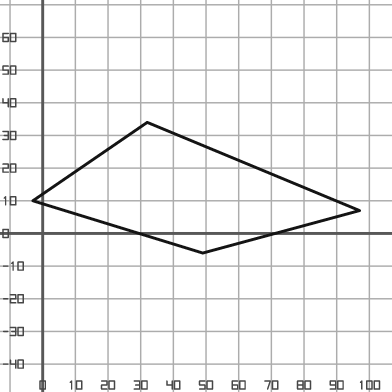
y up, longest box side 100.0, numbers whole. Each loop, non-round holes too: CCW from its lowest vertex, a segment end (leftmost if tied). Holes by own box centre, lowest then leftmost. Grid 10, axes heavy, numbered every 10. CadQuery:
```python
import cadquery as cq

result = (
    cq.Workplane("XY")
    .moveTo(49.0, -6.0)
    .lineTo(97.0, 7.0)
    .lineTo(32.0, 34.0)
    .lineTo(-3.0, 10.0)
    .close()
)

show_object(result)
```